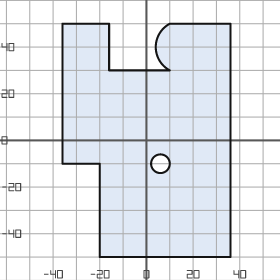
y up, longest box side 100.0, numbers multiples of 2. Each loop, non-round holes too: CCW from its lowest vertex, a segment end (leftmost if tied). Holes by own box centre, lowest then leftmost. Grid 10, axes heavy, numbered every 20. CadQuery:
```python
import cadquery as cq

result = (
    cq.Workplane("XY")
    .moveTo(-20.0, -50.0)
    .lineTo(36.0, -50.0)
    .lineTo(36.0, 50.0)
    .lineTo(10.0, 50.0)
    .threePointArc((4.0, 40.0), (10.0, 30.0))
    .lineTo(-16.0, 30.0)
    .lineTo(-16.0, 50.0)
    .lineTo(-36.0, 50.0)
    .lineTo(-36.0, -10.0)
    .lineTo(-20.0, -10.0)
    .close()
    .moveTo(6.0, -10.0)
    .circle(4.0)
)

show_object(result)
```